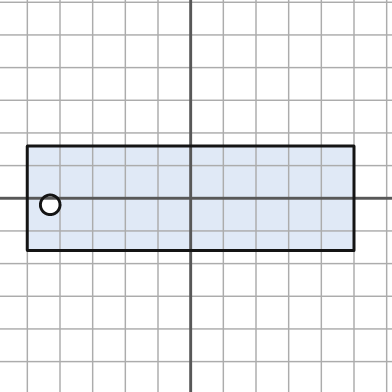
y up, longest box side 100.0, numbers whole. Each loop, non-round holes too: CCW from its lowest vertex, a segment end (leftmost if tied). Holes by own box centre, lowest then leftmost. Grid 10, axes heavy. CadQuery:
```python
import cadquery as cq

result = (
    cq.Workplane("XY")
    .moveTo(-50.0, -16.0)
    .lineTo(50.0, -16.0)
    .lineTo(50.0, 16.0)
    .lineTo(-50.0, 16.0)
    .close()
    .moveTo(-43.0, -2.0)
    .circle(3.0)
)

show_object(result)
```